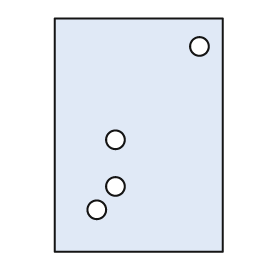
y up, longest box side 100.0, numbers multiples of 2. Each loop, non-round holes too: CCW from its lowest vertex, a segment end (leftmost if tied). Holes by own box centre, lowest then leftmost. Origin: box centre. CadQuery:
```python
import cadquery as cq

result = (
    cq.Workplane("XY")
    .moveTo(-36.0, -50.0)
    .lineTo(36.0, -50.0)
    .lineTo(36.0, 50.0)
    .lineTo(-36.0, 50.0)
    .close()
    .moveTo(-18.0, -32.0)
    .circle(4.0)
    .moveTo(-10.0, -22.0)
    .circle(4.0)
    .moveTo(-10.0, -2.0)
    .circle(4.0)
    .moveTo(26.0, 38.0)
    .circle(4.0)
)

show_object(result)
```